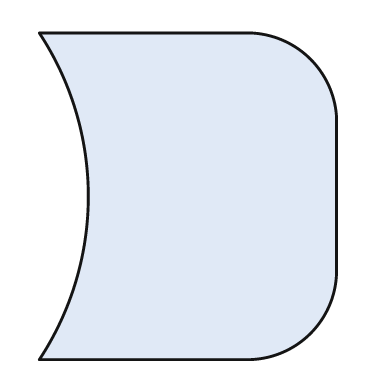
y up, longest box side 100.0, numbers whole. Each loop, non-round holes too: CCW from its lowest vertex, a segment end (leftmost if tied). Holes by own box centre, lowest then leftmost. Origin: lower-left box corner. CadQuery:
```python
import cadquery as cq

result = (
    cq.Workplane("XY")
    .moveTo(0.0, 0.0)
    .lineTo(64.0, 0.0)
    .threePointArc((83.0, 8.0), (91.0, 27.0))
    .lineTo(91.0, 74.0)
    .threePointArc((83.0, 92.0), (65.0, 100.0))
    .lineTo(0.0, 100.0)
    .threePointArc((15.0, 50.0), (0.0, 0.0))
    .close()
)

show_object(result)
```